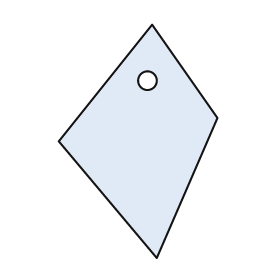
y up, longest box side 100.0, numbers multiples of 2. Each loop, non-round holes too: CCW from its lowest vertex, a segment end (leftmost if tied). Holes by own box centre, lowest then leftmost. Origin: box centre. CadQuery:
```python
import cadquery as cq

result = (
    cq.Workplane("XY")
    .moveTo(8.0, -50.0)
    .lineTo(34.0, 10.0)
    .lineTo(6.0, 50.0)
    .lineTo(-34.0, 0.0)
    .close()
    .moveTo(4.0, 26.0)
    .circle(4.0)
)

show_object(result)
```